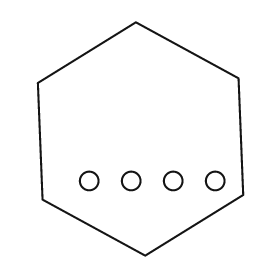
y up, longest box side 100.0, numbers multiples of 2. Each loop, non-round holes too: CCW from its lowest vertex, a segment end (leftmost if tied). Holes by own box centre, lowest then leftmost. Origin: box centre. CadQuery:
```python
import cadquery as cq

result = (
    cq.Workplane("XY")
    .moveTo(2.0, -50.0)
    .lineTo(44.0, -24.0)
    .lineTo(42.0, 26.0)
    .lineTo(-2.0, 50.0)
    .lineTo(-44.0, 24.0)
    .lineTo(-42.0, -26.0)
    .close()
    .moveTo(-22.0, -18.0)
    .circle(4.0)
    .moveTo(-4.0, -18.0)
    .circle(4.0)
    .moveTo(14.0, -18.0)
    .circle(4.0)
    .moveTo(32.0, -18.0)
    .circle(4.0)
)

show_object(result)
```